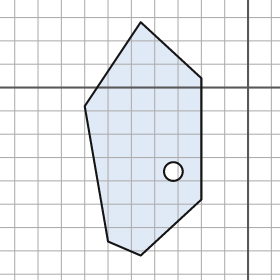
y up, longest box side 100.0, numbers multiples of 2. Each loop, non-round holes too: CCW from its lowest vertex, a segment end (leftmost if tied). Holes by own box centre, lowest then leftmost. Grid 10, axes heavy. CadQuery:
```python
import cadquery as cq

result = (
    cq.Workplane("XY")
    .moveTo(-46.0, -72.0)
    .lineTo(-20.0, -48.0)
    .lineTo(-20.0, 4.0)
    .lineTo(-46.0, 28.0)
    .lineTo(-70.0, -8.0)
    .lineTo(-60.0, -66.0)
    .close()
    .moveTo(-32.0, -36.0)
    .circle(4.0)
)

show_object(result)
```